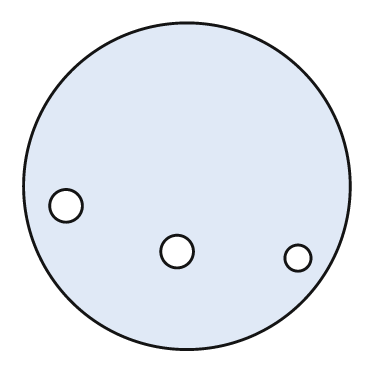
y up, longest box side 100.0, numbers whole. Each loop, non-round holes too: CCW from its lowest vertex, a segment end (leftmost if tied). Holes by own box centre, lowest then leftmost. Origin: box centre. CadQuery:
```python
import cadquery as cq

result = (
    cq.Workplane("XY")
    .moveTo(0.0, 0.0)
    .circle(50.0)
    .moveTo(34.0, -22.0)
    .circle(4.0)
    .moveTo(-3.0, -20.0)
    .circle(5.0)
    .moveTo(-37.0, -6.0)
    .circle(5.0)
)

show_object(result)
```